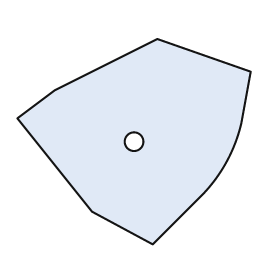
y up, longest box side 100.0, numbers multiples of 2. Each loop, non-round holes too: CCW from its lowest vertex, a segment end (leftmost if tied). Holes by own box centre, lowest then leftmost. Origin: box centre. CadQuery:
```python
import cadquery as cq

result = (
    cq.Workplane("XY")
    .moveTo(8.0, -44.0)
    .lineTo(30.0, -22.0)
    .threePointArc((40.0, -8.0), (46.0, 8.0))
    .lineTo(50.0, 30.0)
    .lineTo(10.0, 44.0)
    .lineTo(-34.0, 22.0)
    .lineTo(-50.0, 10.0)
    .lineTo(-18.0, -30.0)
    .close()
    .moveTo(0.0, 0.0)
    .circle(4.0)
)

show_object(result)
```